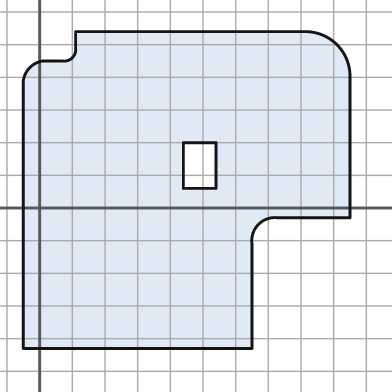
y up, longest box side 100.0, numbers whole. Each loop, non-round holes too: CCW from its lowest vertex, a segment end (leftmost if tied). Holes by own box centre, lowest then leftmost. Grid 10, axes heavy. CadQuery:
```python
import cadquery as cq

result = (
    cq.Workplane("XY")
    .moveTo(-5.0, -43.0)
    .lineTo(65.0, -43.0)
    .lineTo(65.0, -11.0)
    .threePointArc((67.0, -5.0), (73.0, -3.0))
    .lineTo(95.0, -3.0)
    .lineTo(95.0, 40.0)
    .threePointArc((91.0, 50.0), (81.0, 54.0))
    .lineTo(11.0, 54.0)
    .lineTo(11.0, 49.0)
    .threePointArc((10.0, 46.0), (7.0, 45.0))
    .lineTo(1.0, 45.0)
    .threePointArc((-3.0, 43.0), (-5.0, 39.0))
    .close()
    .moveTo(44.0, 6.0)
    .lineTo(54.0, 6.0)
    .lineTo(54.0, 20.0)
    .lineTo(44.0, 20.0)
    .close()
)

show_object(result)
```